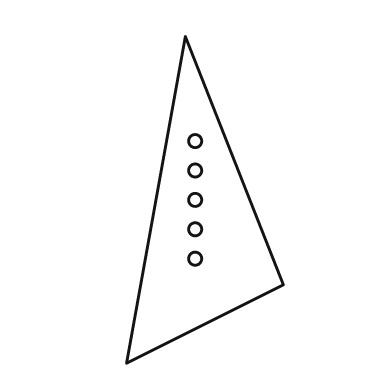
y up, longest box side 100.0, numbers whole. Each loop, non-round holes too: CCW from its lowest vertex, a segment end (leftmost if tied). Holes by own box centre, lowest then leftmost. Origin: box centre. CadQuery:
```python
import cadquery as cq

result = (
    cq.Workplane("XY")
    .moveTo(-24.0, -50.0)
    .lineTo(24.0, -26.0)
    .lineTo(-6.0, 50.0)
    .close()
    .moveTo(-3.0, -18.0)
    .circle(2.0)
    .moveTo(-3.0, -9.0)
    .circle(2.0)
    .moveTo(-3.0, 0.0)
    .circle(2.0)
    .moveTo(-3.0, 9.0)
    .circle(2.0)
    .moveTo(-3.0, 18.0)
    .circle(2.0)
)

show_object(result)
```